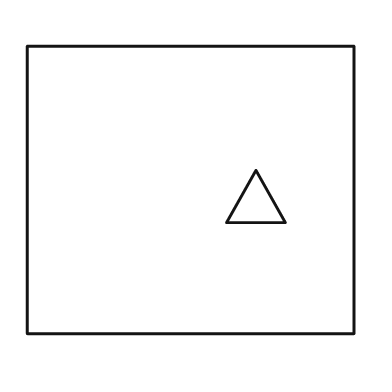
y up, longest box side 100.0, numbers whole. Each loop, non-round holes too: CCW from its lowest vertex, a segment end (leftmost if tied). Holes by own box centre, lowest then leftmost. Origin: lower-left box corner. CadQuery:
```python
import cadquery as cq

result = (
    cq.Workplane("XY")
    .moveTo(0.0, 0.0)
    .lineTo(100.0, 0.0)
    .lineTo(100.0, 88.0)
    .lineTo(0.0, 88.0)
    .close()
    .moveTo(61.0, 34.0)
    .lineTo(79.0, 34.0)
    .lineTo(70.0, 50.0)
    .close()
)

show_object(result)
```